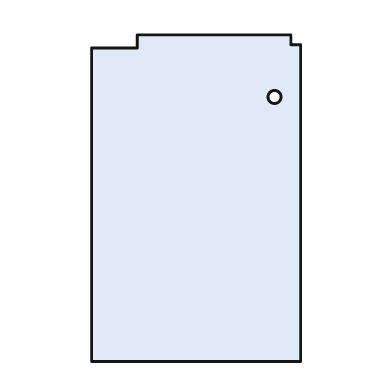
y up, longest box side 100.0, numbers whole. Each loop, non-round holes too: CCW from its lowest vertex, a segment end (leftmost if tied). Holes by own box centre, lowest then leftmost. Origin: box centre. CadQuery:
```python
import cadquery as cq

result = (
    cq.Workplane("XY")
    .moveTo(-32.0, -50.0)
    .lineTo(32.0, -50.0)
    .lineTo(32.0, 47.0)
    .lineTo(29.0, 47.0)
    .lineTo(29.0, 50.0)
    .lineTo(-18.0, 50.0)
    .lineTo(-18.0, 46.0)
    .lineTo(-32.0, 46.0)
    .close()
    .moveTo(24.0, 31.0)
    .circle(2.0)
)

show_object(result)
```